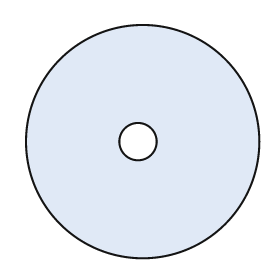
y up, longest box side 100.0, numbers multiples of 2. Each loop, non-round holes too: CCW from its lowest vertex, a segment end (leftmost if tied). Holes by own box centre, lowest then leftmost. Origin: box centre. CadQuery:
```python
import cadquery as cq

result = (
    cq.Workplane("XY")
    .moveTo(0.0, 0.0)
    .circle(50.0)
    .moveTo(-2.0, 0.0)
    .circle(8.0)
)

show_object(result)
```